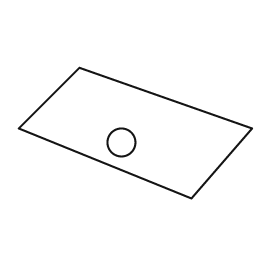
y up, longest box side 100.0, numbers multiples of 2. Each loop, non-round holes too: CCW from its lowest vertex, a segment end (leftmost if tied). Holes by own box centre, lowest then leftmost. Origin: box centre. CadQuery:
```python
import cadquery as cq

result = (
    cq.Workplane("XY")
    .moveTo(24.0, -28.0)
    .lineTo(50.0, 2.0)
    .lineTo(-24.0, 28.0)
    .lineTo(-50.0, 2.0)
    .close()
    .moveTo(-6.0, -4.0)
    .circle(6.0)
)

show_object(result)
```